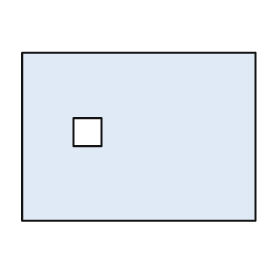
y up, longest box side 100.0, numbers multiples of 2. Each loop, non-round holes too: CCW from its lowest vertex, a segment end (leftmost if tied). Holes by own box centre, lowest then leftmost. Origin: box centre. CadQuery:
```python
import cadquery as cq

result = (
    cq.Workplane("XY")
    .moveTo(-50.0, -36.0)
    .lineTo(50.0, -36.0)
    .lineTo(50.0, 36.0)
    .lineTo(-50.0, 36.0)
    .close()
    .moveTo(-28.0, -4.0)
    .lineTo(-16.0, -4.0)
    .lineTo(-16.0, 8.0)
    .lineTo(-28.0, 8.0)
    .close()
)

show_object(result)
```